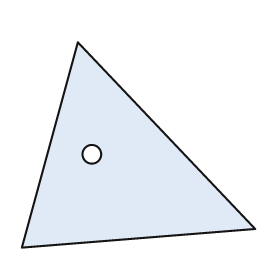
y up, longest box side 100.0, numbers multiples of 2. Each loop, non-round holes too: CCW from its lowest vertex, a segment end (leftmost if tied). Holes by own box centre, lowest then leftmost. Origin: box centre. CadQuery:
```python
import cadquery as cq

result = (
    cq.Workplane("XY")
    .moveTo(-50.0, -44.0)
    .lineTo(50.0, -36.0)
    .lineTo(-26.0, 44.0)
    .close()
    .moveTo(-20.0, -4.0)
    .circle(4.0)
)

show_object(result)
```